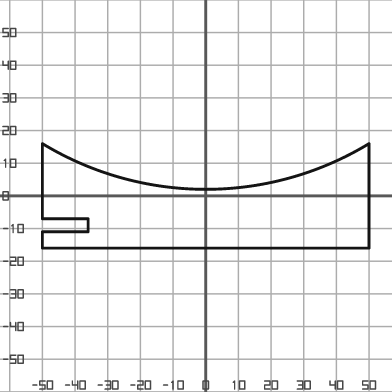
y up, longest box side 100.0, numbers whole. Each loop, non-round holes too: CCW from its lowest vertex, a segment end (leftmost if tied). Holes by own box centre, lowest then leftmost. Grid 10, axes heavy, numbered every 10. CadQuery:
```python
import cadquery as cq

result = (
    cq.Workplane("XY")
    .moveTo(-50.0, -16.0)
    .lineTo(50.0, -16.0)
    .lineTo(50.0, 16.0)
    .threePointArc((0.0, 2.0), (-50.0, 16.0))
    .lineTo(-50.0, -7.0)
    .lineTo(-36.0, -7.0)
    .lineTo(-36.0, -11.0)
    .lineTo(-50.0, -11.0)
    .close()
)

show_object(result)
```